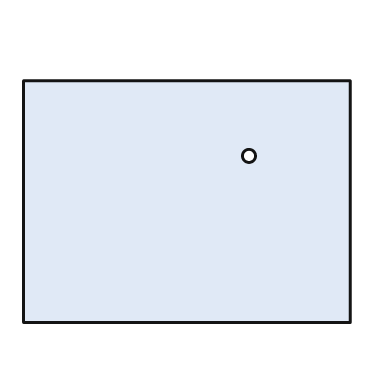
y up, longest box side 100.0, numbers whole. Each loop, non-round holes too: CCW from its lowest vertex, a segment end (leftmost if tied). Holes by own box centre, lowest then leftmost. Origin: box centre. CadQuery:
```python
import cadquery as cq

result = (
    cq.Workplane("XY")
    .moveTo(-50.0, -37.0)
    .lineTo(50.0, -37.0)
    .lineTo(50.0, 37.0)
    .lineTo(-50.0, 37.0)
    .close()
    .moveTo(19.0, 14.0)
    .circle(2.0)
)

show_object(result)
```